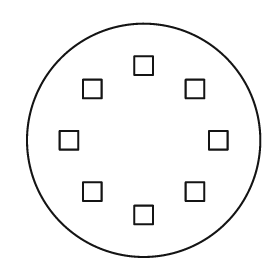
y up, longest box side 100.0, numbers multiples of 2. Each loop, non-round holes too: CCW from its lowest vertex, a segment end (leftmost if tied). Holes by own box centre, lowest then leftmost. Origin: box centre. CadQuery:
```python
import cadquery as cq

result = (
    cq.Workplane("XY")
    .moveTo(0.0, 0.0)
    .circle(50.0)
    .moveTo(-4.0, -36.0)
    .lineTo(4.0, -36.0)
    .lineTo(4.0, -28.0)
    .lineTo(-4.0, -28.0)
    .close()
    .moveTo(-26.0, -26.0)
    .lineTo(-18.0, -26.0)
    .lineTo(-18.0, -18.0)
    .lineTo(-26.0, -18.0)
    .close()
    .moveTo(18.0, -26.0)
    .lineTo(26.0, -26.0)
    .lineTo(26.0, -18.0)
    .lineTo(18.0, -18.0)
    .close()
    .moveTo(-36.0, -4.0)
    .lineTo(-28.0, -4.0)
    .lineTo(-28.0, 4.0)
    .lineTo(-36.0, 4.0)
    .close()
    .moveTo(28.0, -4.0)
    .lineTo(36.0, -4.0)
    .lineTo(36.0, 4.0)
    .lineTo(28.0, 4.0)
    .close()
    .moveTo(-26.0, 18.0)
    .lineTo(-18.0, 18.0)
    .lineTo(-18.0, 26.0)
    .lineTo(-26.0, 26.0)
    .close()
    .moveTo(18.0, 18.0)
    .lineTo(26.0, 18.0)
    .lineTo(26.0, 26.0)
    .lineTo(18.0, 26.0)
    .close()
    .moveTo(-4.0, 28.0)
    .lineTo(4.0, 28.0)
    .lineTo(4.0, 36.0)
    .lineTo(-4.0, 36.0)
    .close()
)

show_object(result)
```